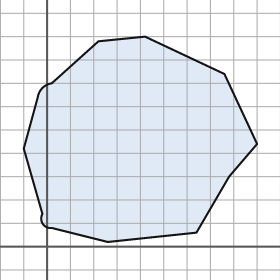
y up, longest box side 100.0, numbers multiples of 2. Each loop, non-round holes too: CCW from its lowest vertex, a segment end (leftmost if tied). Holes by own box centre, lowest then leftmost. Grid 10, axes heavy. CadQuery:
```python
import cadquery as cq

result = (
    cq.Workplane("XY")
    .moveTo(26.0, 2.0)
    .lineTo(64.0, 6.0)
    .lineTo(78.0, 30.0)
    .lineTo(90.0, 44.0)
    .lineTo(76.0, 74.0)
    .lineTo(42.0, 90.0)
    .lineTo(22.0, 88.0)
    .lineTo(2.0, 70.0)
    .threePointArc((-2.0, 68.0), (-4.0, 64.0))
    .lineTo(-10.0, 42.0)
    .lineTo(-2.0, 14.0)
    .threePointArc((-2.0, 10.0), (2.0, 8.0))
    .close()
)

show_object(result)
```